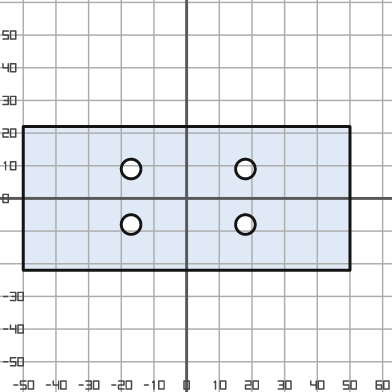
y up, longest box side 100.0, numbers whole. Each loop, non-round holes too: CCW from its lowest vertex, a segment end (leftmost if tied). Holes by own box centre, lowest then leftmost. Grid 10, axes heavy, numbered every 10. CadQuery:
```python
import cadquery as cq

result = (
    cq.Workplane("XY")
    .moveTo(-50.0, -22.0)
    .lineTo(50.0, -22.0)
    .lineTo(50.0, 22.0)
    .lineTo(-50.0, 22.0)
    .close()
    .moveTo(-17.0, -8.0)
    .circle(3.0)
    .moveTo(18.0, -8.0)
    .circle(3.0)
    .moveTo(-17.0, 9.0)
    .circle(3.0)
    .moveTo(18.0, 9.0)
    .circle(3.0)
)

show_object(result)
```